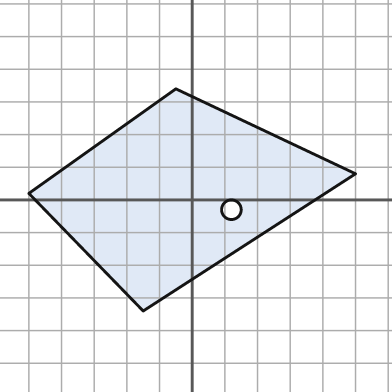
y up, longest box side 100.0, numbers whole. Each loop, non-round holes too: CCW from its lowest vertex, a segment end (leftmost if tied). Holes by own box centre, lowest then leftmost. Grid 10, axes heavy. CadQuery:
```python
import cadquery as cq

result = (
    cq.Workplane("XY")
    .moveTo(-15.0, -34.0)
    .lineTo(50.0, 8.0)
    .lineTo(-5.0, 34.0)
    .lineTo(-50.0, 2.0)
    .close()
    .moveTo(12.0, -3.0)
    .circle(3.0)
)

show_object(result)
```